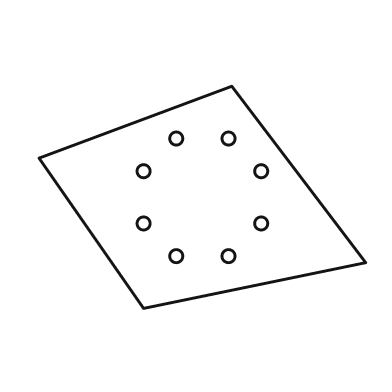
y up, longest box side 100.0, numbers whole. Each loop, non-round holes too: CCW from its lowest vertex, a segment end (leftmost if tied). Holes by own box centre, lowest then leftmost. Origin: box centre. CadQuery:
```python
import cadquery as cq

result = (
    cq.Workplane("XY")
    .moveTo(-18.0, -34.0)
    .lineTo(50.0, -20.0)
    .lineTo(9.0, 34.0)
    .lineTo(-50.0, 12.0)
    .close()
    .moveTo(-8.0, -18.0)
    .circle(2.0)
    .moveTo(8.0, -18.0)
    .circle(2.0)
    .moveTo(-18.0, -8.0)
    .circle(2.0)
    .moveTo(18.0, -8.0)
    .circle(2.0)
    .moveTo(-18.0, 8.0)
    .circle(2.0)
    .moveTo(18.0, 8.0)
    .circle(2.0)
    .moveTo(-8.0, 18.0)
    .circle(2.0)
    .moveTo(8.0, 18.0)
    .circle(2.0)
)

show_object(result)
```